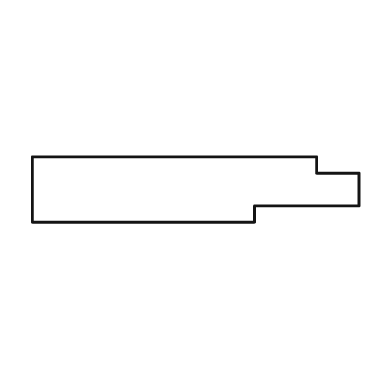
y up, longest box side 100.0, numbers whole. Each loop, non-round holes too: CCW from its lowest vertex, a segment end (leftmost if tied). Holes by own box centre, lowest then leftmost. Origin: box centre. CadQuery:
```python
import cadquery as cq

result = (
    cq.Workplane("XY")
    .moveTo(-50.0, -10.0)
    .lineTo(18.0, -10.0)
    .lineTo(18.0, -5.0)
    .lineTo(50.0, -5.0)
    .lineTo(50.0, 5.0)
    .lineTo(37.0, 5.0)
    .lineTo(37.0, 10.0)
    .lineTo(-50.0, 10.0)
    .close()
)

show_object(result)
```